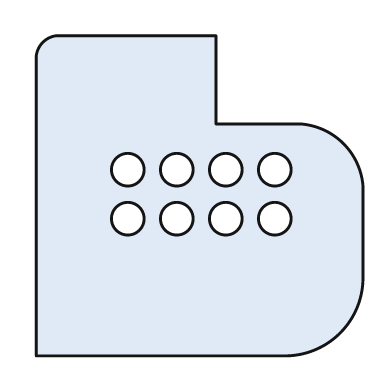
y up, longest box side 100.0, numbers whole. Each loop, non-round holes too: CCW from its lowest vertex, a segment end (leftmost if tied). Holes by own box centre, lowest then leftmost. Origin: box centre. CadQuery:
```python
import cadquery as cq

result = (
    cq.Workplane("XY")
    .moveTo(-50.0, -49.0)
    .lineTo(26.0, -49.0)
    .threePointArc((43.0, -42.0), (50.0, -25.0))
    .lineTo(50.0, 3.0)
    .threePointArc((44.0, 16.0), (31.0, 22.0))
    .lineTo(5.0, 22.0)
    .lineTo(5.0, 49.0)
    .lineTo(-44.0, 49.0)
    .threePointArc((-48.0, 47.0), (-50.0, 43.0))
    .close()
    .moveTo(-22.0, -7.0)
    .circle(5.0)
    .moveTo(-7.0, -7.0)
    .circle(5.0)
    .moveTo(8.0, -7.0)
    .circle(5.0)
    .moveTo(23.0, -7.0)
    .circle(5.0)
    .moveTo(-22.0, 8.0)
    .circle(5.0)
    .moveTo(-7.0, 8.0)
    .circle(5.0)
    .moveTo(8.0, 8.0)
    .circle(5.0)
    .moveTo(23.0, 8.0)
    .circle(5.0)
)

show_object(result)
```